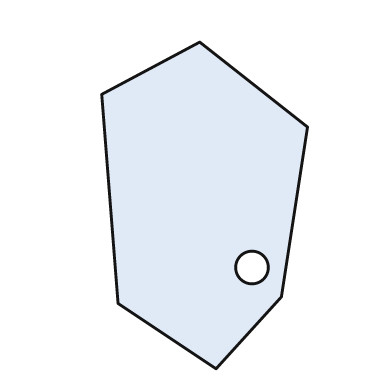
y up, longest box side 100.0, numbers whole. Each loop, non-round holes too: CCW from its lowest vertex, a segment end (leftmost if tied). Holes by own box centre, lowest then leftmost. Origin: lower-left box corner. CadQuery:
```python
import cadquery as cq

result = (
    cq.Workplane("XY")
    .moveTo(35.0, 0.0)
    .lineTo(55.0, 22.0)
    .lineTo(63.0, 74.0)
    .lineTo(30.0, 100.0)
    .lineTo(0.0, 84.0)
    .lineTo(5.0, 20.0)
    .close()
    .moveTo(46.0, 31.0)
    .circle(5.0)
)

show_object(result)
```